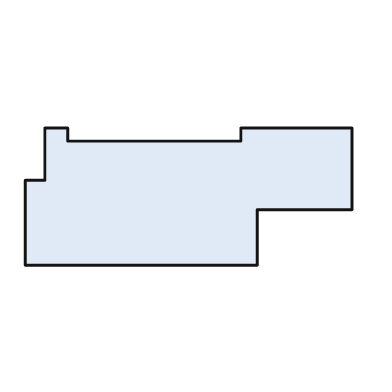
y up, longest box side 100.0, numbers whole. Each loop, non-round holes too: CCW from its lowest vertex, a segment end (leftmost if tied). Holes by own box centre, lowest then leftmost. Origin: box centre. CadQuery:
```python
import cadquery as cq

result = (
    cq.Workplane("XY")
    .moveTo(-50.0, -21.0)
    .lineTo(21.0, -21.0)
    .lineTo(21.0, -4.0)
    .lineTo(50.0, -4.0)
    .lineTo(50.0, 21.0)
    .lineTo(16.0, 21.0)
    .lineTo(16.0, 17.0)
    .lineTo(-37.0, 17.0)
    .lineTo(-37.0, 21.0)
    .lineTo(-44.0, 21.0)
    .lineTo(-44.0, 5.0)
    .lineTo(-50.0, 5.0)
    .close()
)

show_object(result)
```